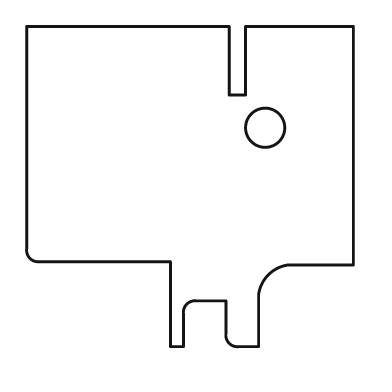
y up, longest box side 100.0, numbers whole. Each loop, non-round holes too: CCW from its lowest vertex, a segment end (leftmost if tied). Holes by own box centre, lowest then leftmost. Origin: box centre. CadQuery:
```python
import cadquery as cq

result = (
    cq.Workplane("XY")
    .moveTo(-6.0, -49.0)
    .lineTo(-2.0, -49.0)
    .lineTo(-2.0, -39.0)
    .threePointArc((-1.0, -36.0), (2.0, -35.0))
    .lineTo(11.0, -35.0)
    .lineTo(11.0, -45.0)
    .threePointArc((12.0, -48.0), (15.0, -49.0))
    .lineTo(21.0, -49.0)
    .lineTo(21.0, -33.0)
    .threePointArc((24.0, -27.0), (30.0, -24.0))
    .lineTo(50.0, -24.0)
    .lineTo(50.0, 49.0)
    .lineTo(17.0, 49.0)
    .lineTo(17.0, 28.0)
    .lineTo(12.0, 28.0)
    .lineTo(12.0, 49.0)
    .lineTo(-50.0, 49.0)
    .lineTo(-50.0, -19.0)
    .threePointArc((-49.0, -22.0), (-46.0, -23.0))
    .lineTo(-6.0, -23.0)
    .close()
    .moveTo(23.0, 18.0)
    .circle(6.0)
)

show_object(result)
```